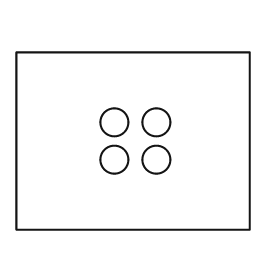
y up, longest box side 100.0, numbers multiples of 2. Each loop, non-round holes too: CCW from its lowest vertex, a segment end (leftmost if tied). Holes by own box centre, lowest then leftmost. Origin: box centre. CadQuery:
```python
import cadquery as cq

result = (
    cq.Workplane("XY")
    .moveTo(-50.0, -38.0)
    .lineTo(50.0, -38.0)
    .lineTo(50.0, 38.0)
    .lineTo(-50.0, 38.0)
    .close()
    .moveTo(-8.0, -8.0)
    .circle(6.0)
    .moveTo(10.0, -8.0)
    .circle(6.0)
    .moveTo(-8.0, 8.0)
    .circle(6.0)
    .moveTo(10.0, 8.0)
    .circle(6.0)
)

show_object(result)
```